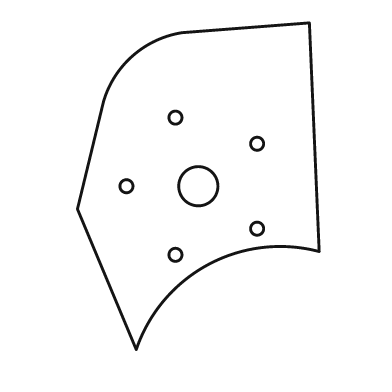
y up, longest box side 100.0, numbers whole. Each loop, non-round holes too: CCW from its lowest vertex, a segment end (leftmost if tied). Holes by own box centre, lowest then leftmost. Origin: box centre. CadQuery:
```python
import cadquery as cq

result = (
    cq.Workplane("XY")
    .moveTo(-19.0, -50.0)
    .threePointArc((3.0, -24.0), (37.0, -20.0))
    .lineTo(34.0, 50.0)
    .lineTo(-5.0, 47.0)
    .threePointArc((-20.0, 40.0), (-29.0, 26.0))
    .lineTo(-37.0, -7.0)
    .close()
    .moveTo(-7.0, -21.0)
    .circle(2.0)
    .moveTo(18.0, -13.0)
    .circle(2.0)
    .moveTo(-22.0, 0.0)
    .circle(2.0)
    .moveTo(0.0, 0.0)
    .circle(6.0)
    .moveTo(18.0, 13.0)
    .circle(2.0)
    .moveTo(-7.0, 21.0)
    .circle(2.0)
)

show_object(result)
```